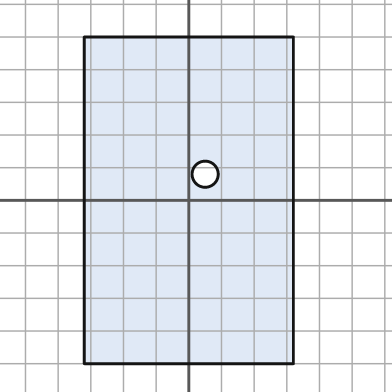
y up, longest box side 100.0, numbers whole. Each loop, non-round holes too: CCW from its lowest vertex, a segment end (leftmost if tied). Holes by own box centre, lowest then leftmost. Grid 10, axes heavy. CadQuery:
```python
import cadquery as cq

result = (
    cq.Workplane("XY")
    .moveTo(-32.0, -50.0)
    .lineTo(32.0, -50.0)
    .lineTo(32.0, 50.0)
    .lineTo(-32.0, 50.0)
    .close()
    .moveTo(5.0, 8.0)
    .circle(4.0)
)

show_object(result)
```